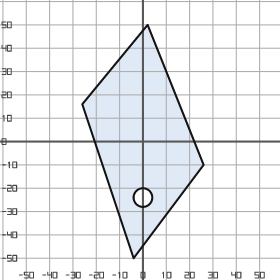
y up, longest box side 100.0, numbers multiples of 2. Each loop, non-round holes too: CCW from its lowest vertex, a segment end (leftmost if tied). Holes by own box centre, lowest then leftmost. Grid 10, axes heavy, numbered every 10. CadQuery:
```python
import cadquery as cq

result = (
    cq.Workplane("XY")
    .moveTo(-4.0, -50.0)
    .lineTo(26.0, -10.0)
    .lineTo(2.0, 50.0)
    .lineTo(-26.0, 16.0)
    .close()
    .moveTo(0.0, -24.0)
    .circle(4.0)
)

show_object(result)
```